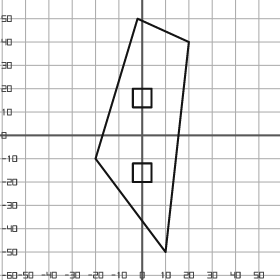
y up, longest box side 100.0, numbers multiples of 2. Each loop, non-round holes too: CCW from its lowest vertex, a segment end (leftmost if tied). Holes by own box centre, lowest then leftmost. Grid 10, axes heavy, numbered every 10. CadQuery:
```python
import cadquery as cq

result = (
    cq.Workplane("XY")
    .moveTo(10.0, -50.0)
    .lineTo(20.0, 40.0)
    .lineTo(-2.0, 50.0)
    .lineTo(-20.0, -10.0)
    .close()
    .moveTo(-4.0, -20.0)
    .lineTo(4.0, -20.0)
    .lineTo(4.0, -12.0)
    .lineTo(-4.0, -12.0)
    .close()
    .moveTo(-4.0, 12.0)
    .lineTo(4.0, 12.0)
    .lineTo(4.0, 20.0)
    .lineTo(-4.0, 20.0)
    .close()
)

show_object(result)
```